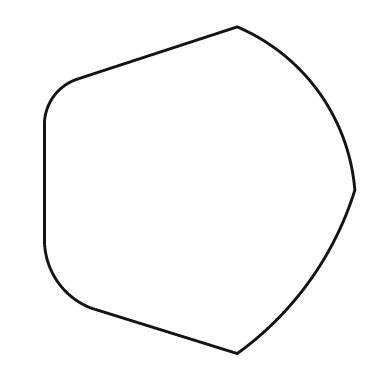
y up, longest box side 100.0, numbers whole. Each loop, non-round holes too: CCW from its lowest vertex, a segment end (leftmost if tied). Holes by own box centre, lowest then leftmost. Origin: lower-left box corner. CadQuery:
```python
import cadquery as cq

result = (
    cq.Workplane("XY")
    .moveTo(59.0, 0.0)
    .threePointArc((81.0, 22.0), (95.0, 50.0))
    .threePointArc((84.0, 80.0), (59.0, 100.0))
    .lineTo(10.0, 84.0)
    .threePointArc((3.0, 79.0), (0.0, 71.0))
    .lineTo(0.0, 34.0)
    .threePointArc((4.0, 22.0), (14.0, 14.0))
    .close()
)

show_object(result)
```